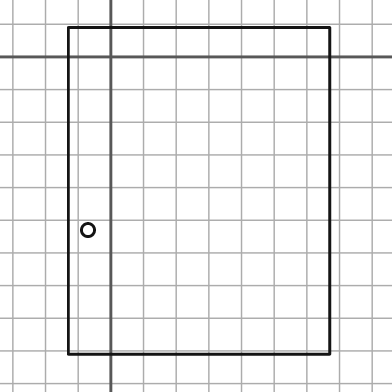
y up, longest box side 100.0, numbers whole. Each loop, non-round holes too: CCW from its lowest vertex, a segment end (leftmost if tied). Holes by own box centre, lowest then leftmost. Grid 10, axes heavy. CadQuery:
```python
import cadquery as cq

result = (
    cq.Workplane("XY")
    .moveTo(-13.0, -91.0)
    .lineTo(67.0, -91.0)
    .lineTo(67.0, 9.0)
    .lineTo(-13.0, 9.0)
    .close()
    .moveTo(-7.0, -53.0)
    .circle(2.0)
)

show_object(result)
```